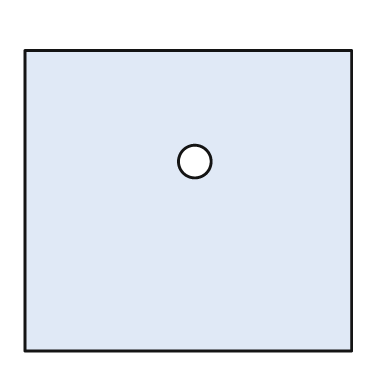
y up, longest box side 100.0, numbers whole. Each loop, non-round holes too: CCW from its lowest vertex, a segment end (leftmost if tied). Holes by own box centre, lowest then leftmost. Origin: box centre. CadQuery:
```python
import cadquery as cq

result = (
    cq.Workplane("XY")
    .moveTo(-50.0, -46.0)
    .lineTo(50.0, -46.0)
    .lineTo(50.0, 46.0)
    .lineTo(-50.0, 46.0)
    .close()
    .moveTo(2.0, 12.0)
    .circle(5.0)
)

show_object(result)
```